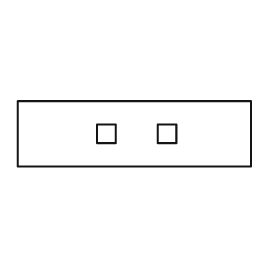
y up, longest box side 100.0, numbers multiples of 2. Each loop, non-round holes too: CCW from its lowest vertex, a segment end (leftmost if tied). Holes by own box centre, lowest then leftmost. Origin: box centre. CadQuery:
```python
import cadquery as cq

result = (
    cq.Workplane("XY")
    .moveTo(-50.0, -14.0)
    .lineTo(50.0, -14.0)
    .lineTo(50.0, 14.0)
    .lineTo(-50.0, 14.0)
    .close()
    .moveTo(-16.0, -4.0)
    .lineTo(-8.0, -4.0)
    .lineTo(-8.0, 4.0)
    .lineTo(-16.0, 4.0)
    .close()
    .moveTo(10.0, -4.0)
    .lineTo(18.0, -4.0)
    .lineTo(18.0, 4.0)
    .lineTo(10.0, 4.0)
    .close()
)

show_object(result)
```